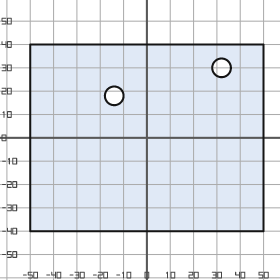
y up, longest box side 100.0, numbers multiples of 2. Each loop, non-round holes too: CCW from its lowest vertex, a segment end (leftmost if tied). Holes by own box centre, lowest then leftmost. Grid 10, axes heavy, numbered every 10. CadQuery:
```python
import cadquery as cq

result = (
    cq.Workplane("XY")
    .moveTo(-50.0, -40.0)
    .lineTo(50.0, -40.0)
    .lineTo(50.0, 40.0)
    .lineTo(-50.0, 40.0)
    .close()
    .moveTo(-14.0, 18.0)
    .circle(4.0)
    .moveTo(32.0, 30.0)
    .circle(4.0)
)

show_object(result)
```